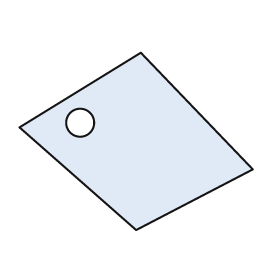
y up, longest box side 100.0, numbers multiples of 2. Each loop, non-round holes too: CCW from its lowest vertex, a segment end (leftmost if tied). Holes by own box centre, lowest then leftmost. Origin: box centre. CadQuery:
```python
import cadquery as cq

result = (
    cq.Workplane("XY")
    .moveTo(0.0, -38.0)
    .lineTo(50.0, -12.0)
    .lineTo(2.0, 38.0)
    .lineTo(-50.0, 6.0)
    .close()
    .moveTo(-24.0, 8.0)
    .circle(6.0)
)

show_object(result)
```